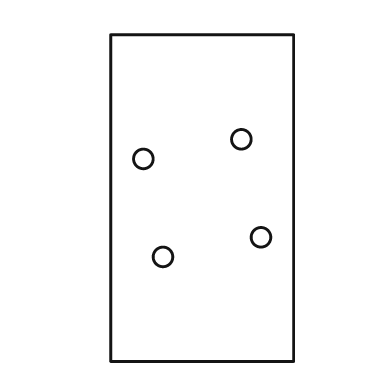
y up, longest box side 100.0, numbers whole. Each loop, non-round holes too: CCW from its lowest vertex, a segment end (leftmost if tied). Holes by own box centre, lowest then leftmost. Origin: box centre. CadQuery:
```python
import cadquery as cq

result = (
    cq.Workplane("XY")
    .moveTo(-28.0, -50.0)
    .lineTo(28.0, -50.0)
    .lineTo(28.0, 50.0)
    .lineTo(-28.0, 50.0)
    .close()
    .moveTo(-12.0, -18.0)
    .circle(3.0)
    .moveTo(18.0, -12.0)
    .circle(3.0)
    .moveTo(-18.0, 12.0)
    .circle(3.0)
    .moveTo(12.0, 18.0)
    .circle(3.0)
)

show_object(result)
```